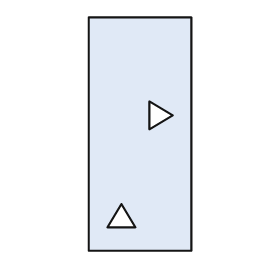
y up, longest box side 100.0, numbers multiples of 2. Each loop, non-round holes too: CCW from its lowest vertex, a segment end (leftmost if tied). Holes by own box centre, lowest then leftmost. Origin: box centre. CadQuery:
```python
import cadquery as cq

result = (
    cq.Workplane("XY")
    .moveTo(-22.0, -50.0)
    .lineTo(22.0, -50.0)
    .lineTo(22.0, 50.0)
    .lineTo(-22.0, 50.0)
    .close()
    .moveTo(-14.0, -40.0)
    .lineTo(-2.0, -40.0)
    .lineTo(-8.0, -30.0)
    .close()
    .moveTo(4.0, 2.0)
    .lineTo(14.0, 8.0)
    .lineTo(4.0, 14.0)
    .close()
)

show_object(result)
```